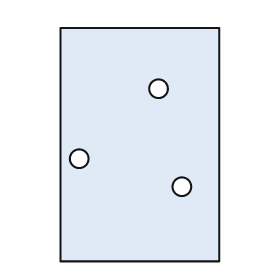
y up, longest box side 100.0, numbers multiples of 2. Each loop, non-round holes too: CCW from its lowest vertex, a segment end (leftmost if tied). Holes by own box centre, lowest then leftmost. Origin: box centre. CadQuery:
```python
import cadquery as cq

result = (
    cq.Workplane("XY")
    .moveTo(-34.0, -50.0)
    .lineTo(34.0, -50.0)
    .lineTo(34.0, 50.0)
    .lineTo(-34.0, 50.0)
    .close()
    .moveTo(18.0, -18.0)
    .circle(4.0)
    .moveTo(-26.0, -6.0)
    .circle(4.0)
    .moveTo(8.0, 24.0)
    .circle(4.0)
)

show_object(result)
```